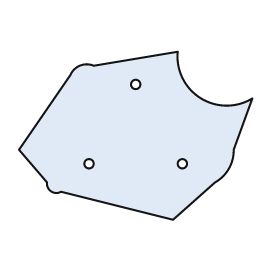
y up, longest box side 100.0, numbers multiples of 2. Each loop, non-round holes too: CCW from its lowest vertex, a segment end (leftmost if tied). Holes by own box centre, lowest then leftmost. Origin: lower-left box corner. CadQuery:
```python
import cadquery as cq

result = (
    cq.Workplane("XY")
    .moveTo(66.0, 0.0)
    .lineTo(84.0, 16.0)
    .threePointArc((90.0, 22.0), (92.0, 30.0))
    .lineTo(100.0, 52.0)
    .threePointArc((78.0, 52.0), (68.0, 72.0))
    .lineTo(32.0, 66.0)
    .threePointArc((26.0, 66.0), (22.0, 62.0))
    .lineTo(0.0, 30.0)
    .lineTo(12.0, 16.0)
    .threePointArc((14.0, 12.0), (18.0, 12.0))
    .close()
    .moveTo(30.0, 24.0)
    .circle(2.0)
    .moveTo(70.0, 24.0)
    .circle(2.0)
    .moveTo(50.0, 58.0)
    .circle(2.0)
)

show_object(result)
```